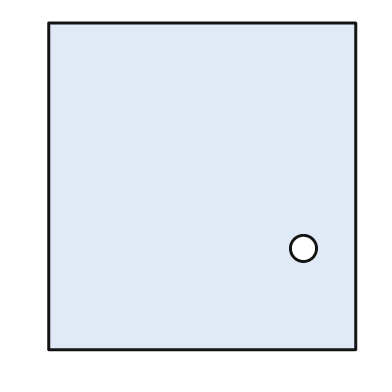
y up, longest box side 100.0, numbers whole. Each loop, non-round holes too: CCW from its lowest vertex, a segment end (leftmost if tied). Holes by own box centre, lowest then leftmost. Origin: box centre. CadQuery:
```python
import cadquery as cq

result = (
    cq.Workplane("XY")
    .moveTo(-47.0, -50.0)
    .lineTo(47.0, -50.0)
    .lineTo(47.0, 50.0)
    .lineTo(-47.0, 50.0)
    .close()
    .moveTo(31.0, -19.0)
    .circle(4.0)
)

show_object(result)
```